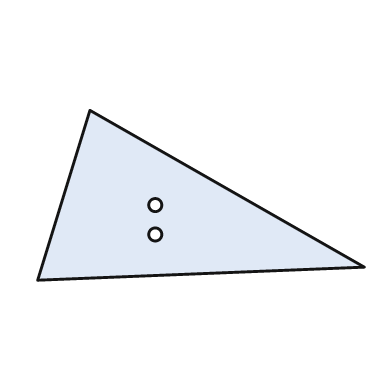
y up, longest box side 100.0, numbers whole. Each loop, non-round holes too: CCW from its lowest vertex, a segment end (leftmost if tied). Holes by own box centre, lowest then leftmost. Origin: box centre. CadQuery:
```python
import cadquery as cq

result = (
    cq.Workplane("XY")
    .moveTo(-50.0, -26.0)
    .lineTo(50.0, -22.0)
    .lineTo(-34.0, 26.0)
    .close()
    .moveTo(-14.0, -12.0)
    .circle(2.0)
    .moveTo(-14.0, -3.0)
    .circle(2.0)
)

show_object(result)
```